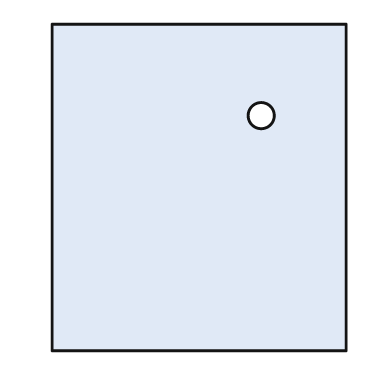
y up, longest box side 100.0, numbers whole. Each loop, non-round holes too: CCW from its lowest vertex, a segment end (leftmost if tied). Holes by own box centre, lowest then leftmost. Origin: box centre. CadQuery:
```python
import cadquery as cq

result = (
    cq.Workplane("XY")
    .moveTo(-45.0, -50.0)
    .lineTo(45.0, -50.0)
    .lineTo(45.0, 50.0)
    .lineTo(-45.0, 50.0)
    .close()
    .moveTo(19.0, 22.0)
    .circle(4.0)
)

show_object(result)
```